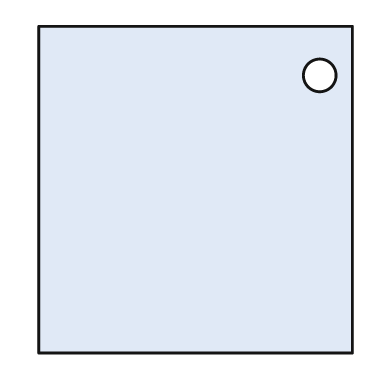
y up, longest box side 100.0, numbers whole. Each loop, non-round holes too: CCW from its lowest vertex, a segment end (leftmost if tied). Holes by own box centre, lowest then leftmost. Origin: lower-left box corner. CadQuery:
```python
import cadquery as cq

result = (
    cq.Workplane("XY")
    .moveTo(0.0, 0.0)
    .lineTo(96.0, 0.0)
    .lineTo(96.0, 100.0)
    .lineTo(0.0, 100.0)
    .close()
    .moveTo(86.0, 85.0)
    .circle(5.0)
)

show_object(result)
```